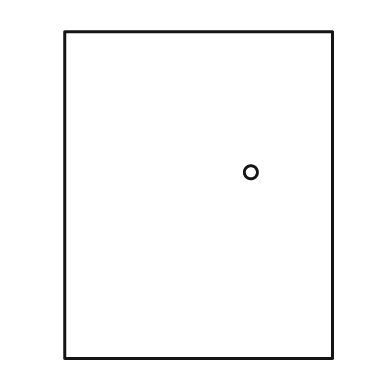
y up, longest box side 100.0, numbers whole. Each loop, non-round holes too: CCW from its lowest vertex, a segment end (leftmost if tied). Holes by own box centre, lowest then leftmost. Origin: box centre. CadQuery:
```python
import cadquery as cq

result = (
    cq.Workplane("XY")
    .moveTo(-41.0, -50.0)
    .lineTo(41.0, -50.0)
    .lineTo(41.0, 50.0)
    .lineTo(-41.0, 50.0)
    .close()
    .moveTo(16.0, 7.0)
    .circle(2.0)
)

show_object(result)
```